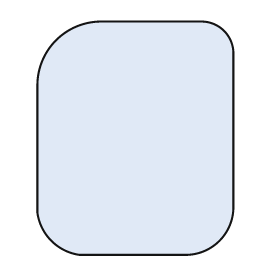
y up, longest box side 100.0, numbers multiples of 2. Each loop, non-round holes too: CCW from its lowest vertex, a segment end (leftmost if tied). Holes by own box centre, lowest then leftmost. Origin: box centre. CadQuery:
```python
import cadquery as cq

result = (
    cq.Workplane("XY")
    .moveTo(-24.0, -50.0)
    .lineTo(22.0, -50.0)
    .threePointArc((36.0, -44.0), (42.0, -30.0))
    .lineTo(42.0, 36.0)
    .threePointArc((38.0, 46.0), (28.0, 50.0))
    .lineTo(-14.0, 50.0)
    .threePointArc((-34.0, 42.0), (-42.0, 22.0))
    .lineTo(-42.0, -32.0)
    .threePointArc((-36.0, -44.0), (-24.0, -50.0))
    .close()
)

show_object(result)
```